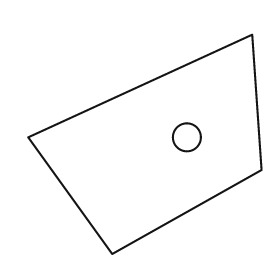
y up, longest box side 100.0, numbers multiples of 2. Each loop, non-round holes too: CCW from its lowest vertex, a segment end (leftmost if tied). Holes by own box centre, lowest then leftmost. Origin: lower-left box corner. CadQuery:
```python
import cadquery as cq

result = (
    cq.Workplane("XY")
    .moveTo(36.0, 0.0)
    .lineTo(100.0, 36.0)
    .lineTo(96.0, 94.0)
    .lineTo(0.0, 50.0)
    .close()
    .moveTo(68.0, 50.0)
    .circle(6.0)
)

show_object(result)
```